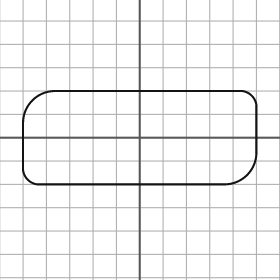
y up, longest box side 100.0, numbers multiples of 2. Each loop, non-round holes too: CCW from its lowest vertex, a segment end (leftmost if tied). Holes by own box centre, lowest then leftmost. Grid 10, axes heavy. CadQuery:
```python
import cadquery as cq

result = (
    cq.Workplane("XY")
    .moveTo(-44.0, -20.0)
    .lineTo(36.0, -20.0)
    .threePointArc((46.0, -16.0), (50.0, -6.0))
    .lineTo(50.0, 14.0)
    .threePointArc((48.0, 18.0), (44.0, 20.0))
    .lineTo(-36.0, 20.0)
    .threePointArc((-46.0, 16.0), (-50.0, 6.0))
    .lineTo(-50.0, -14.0)
    .threePointArc((-48.0, -18.0), (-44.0, -20.0))
    .close()
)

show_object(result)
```